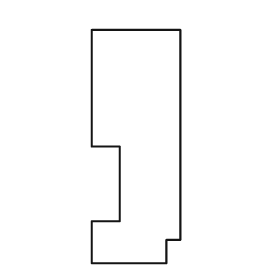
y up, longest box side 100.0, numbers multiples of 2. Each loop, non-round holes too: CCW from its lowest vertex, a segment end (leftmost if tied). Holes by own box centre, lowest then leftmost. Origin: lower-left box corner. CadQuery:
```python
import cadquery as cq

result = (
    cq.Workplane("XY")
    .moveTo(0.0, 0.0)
    .lineTo(32.0, 0.0)
    .lineTo(32.0, 10.0)
    .lineTo(38.0, 10.0)
    .lineTo(38.0, 100.0)
    .lineTo(0.0, 100.0)
    .lineTo(0.0, 50.0)
    .lineTo(12.0, 50.0)
    .lineTo(12.0, 18.0)
    .lineTo(0.0, 18.0)
    .close()
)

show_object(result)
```